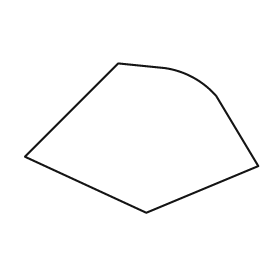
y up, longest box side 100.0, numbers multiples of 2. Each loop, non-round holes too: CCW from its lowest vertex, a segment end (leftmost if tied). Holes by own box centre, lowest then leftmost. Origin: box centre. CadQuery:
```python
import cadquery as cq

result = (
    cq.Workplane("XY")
    .moveTo(2.0, -32.0)
    .lineTo(50.0, -12.0)
    .lineTo(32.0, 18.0)
    .threePointArc((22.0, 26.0), (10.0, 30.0))
    .lineTo(-10.0, 32.0)
    .lineTo(-50.0, -8.0)
    .close()
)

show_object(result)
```